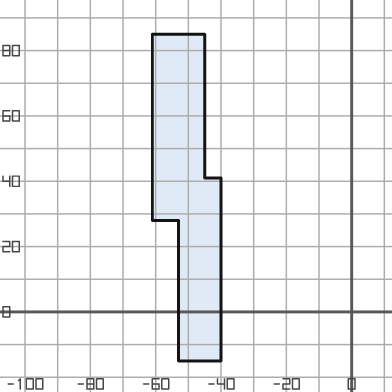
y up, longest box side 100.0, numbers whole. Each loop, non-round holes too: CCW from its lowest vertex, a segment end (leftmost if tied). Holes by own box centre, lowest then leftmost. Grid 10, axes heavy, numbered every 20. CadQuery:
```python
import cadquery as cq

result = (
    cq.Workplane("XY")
    .moveTo(-53.0, -15.0)
    .lineTo(-40.0, -15.0)
    .lineTo(-40.0, 41.0)
    .lineTo(-45.0, 41.0)
    .lineTo(-45.0, 85.0)
    .lineTo(-61.0, 85.0)
    .lineTo(-61.0, 28.0)
    .lineTo(-53.0, 28.0)
    .close()
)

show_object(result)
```